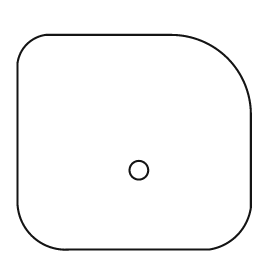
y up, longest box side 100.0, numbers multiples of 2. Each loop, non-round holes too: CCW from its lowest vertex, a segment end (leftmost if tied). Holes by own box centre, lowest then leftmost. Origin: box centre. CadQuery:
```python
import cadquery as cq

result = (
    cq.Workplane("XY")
    .moveTo(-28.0, -46.0)
    .lineTo(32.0, -46.0)
    .threePointArc((44.0, -40.0), (50.0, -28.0))
    .lineTo(50.0, 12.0)
    .threePointArc((40.0, 36.0), (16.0, 46.0))
    .lineTo(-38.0, 46.0)
    .threePointArc((-46.0, 42.0), (-50.0, 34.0))
    .lineTo(-50.0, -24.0)
    .threePointArc((-44.0, -40.0), (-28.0, -46.0))
    .close()
    .moveTo(2.0, -12.0)
    .circle(4.0)
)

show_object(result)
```